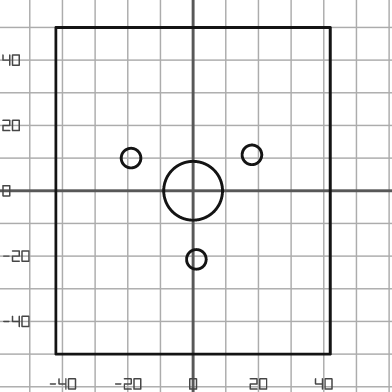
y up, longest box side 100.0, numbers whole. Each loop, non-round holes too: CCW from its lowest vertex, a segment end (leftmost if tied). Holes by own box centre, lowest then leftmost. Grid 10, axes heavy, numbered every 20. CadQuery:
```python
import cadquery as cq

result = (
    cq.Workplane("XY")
    .moveTo(-42.0, -50.0)
    .lineTo(42.0, -50.0)
    .lineTo(42.0, 50.0)
    .lineTo(-42.0, 50.0)
    .close()
    .moveTo(1.0, -21.0)
    .circle(3.0)
    .moveTo(0.0, 0.0)
    .circle(9.0)
    .moveTo(-19.0, 10.0)
    .circle(3.0)
    .moveTo(18.0, 11.0)
    .circle(3.0)
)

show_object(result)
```